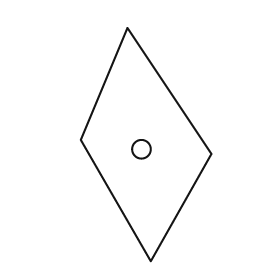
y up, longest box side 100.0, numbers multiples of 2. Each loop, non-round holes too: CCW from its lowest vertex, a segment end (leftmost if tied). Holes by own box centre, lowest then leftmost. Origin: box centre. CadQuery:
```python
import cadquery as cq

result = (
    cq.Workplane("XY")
    .moveTo(2.0, -50.0)
    .lineTo(28.0, -4.0)
    .lineTo(-8.0, 50.0)
    .lineTo(-28.0, 2.0)
    .close()
    .moveTo(-2.0, -2.0)
    .circle(4.0)
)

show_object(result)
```